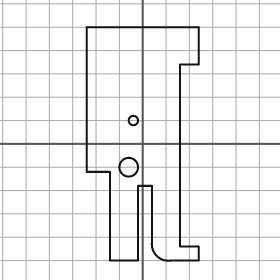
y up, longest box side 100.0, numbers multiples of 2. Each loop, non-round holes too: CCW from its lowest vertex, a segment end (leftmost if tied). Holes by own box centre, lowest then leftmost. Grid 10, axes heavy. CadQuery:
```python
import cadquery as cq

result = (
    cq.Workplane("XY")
    .moveTo(-14.0, -50.0)
    .lineTo(-2.0, -50.0)
    .lineTo(-2.0, -18.0)
    .lineTo(4.0, -18.0)
    .lineTo(4.0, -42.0)
    .threePointArc((6.0, -48.0), (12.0, -50.0))
    .lineTo(24.0, -50.0)
    .lineTo(24.0, -44.0)
    .lineTo(16.0, -44.0)
    .lineTo(16.0, 34.0)
    .lineTo(24.0, 34.0)
    .lineTo(24.0, 50.0)
    .lineTo(-24.0, 50.0)
    .lineTo(-24.0, -12.0)
    .lineTo(-14.0, -12.0)
    .close()
    .moveTo(-6.0, -10.0)
    .circle(4.0)
    .moveTo(-4.0, 10.0)
    .circle(2.0)
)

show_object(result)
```